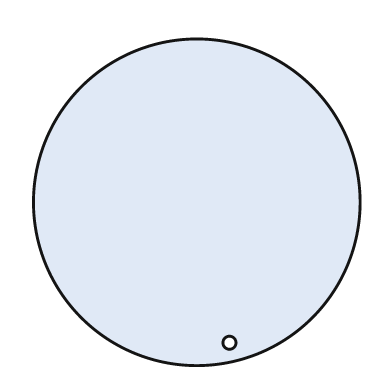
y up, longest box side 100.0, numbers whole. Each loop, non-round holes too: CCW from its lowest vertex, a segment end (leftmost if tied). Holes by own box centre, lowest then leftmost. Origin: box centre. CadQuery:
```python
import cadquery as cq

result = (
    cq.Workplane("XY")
    .moveTo(0.0, 0.0)
    .circle(50.0)
    .moveTo(10.0, -43.0)
    .circle(2.0)
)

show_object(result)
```